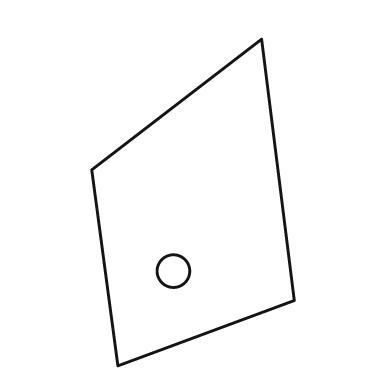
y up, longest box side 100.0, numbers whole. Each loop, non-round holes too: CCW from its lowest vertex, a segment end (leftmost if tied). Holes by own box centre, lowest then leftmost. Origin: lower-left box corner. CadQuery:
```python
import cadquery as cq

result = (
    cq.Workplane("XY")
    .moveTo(8.0, 0.0)
    .lineTo(62.0, 20.0)
    .lineTo(52.0, 100.0)
    .lineTo(0.0, 60.0)
    .close()
    .moveTo(25.0, 29.0)
    .circle(5.0)
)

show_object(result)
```